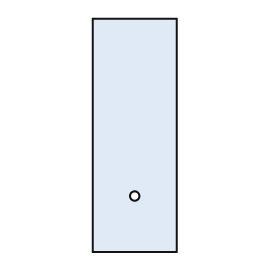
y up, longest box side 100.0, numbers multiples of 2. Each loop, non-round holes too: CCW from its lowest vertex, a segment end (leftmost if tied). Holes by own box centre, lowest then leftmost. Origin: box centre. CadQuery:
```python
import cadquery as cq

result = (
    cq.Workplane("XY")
    .moveTo(-18.0, -50.0)
    .lineTo(18.0, -50.0)
    .lineTo(18.0, 50.0)
    .lineTo(-18.0, 50.0)
    .close()
    .moveTo(0.0, -26.0)
    .circle(2.0)
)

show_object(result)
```